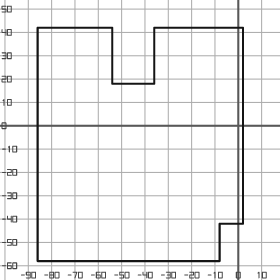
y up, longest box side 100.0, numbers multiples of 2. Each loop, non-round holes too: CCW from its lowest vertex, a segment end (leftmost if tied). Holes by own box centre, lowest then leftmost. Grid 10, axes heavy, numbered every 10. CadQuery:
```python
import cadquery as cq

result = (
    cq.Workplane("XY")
    .moveTo(-86.0, -58.0)
    .lineTo(-8.0, -58.0)
    .lineTo(-8.0, -42.0)
    .lineTo(2.0, -42.0)
    .lineTo(2.0, 42.0)
    .lineTo(-36.0, 42.0)
    .lineTo(-36.0, 18.0)
    .lineTo(-54.0, 18.0)
    .lineTo(-54.0, 42.0)
    .lineTo(-86.0, 42.0)
    .close()
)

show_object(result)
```